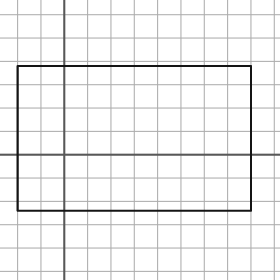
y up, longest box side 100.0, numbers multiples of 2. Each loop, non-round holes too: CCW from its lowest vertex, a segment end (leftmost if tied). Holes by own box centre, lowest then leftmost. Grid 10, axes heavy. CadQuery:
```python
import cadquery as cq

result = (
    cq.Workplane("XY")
    .moveTo(-20.0, -24.0)
    .lineTo(80.0, -24.0)
    .lineTo(80.0, 38.0)
    .lineTo(-20.0, 38.0)
    .close()
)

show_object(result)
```